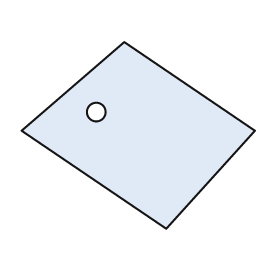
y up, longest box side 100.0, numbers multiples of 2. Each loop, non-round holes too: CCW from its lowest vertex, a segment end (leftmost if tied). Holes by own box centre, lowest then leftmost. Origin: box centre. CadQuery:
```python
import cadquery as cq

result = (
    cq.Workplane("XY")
    .moveTo(12.0, -40.0)
    .lineTo(50.0, 2.0)
    .lineTo(-6.0, 40.0)
    .lineTo(-50.0, 2.0)
    .close()
    .moveTo(-18.0, 10.0)
    .circle(4.0)
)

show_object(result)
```